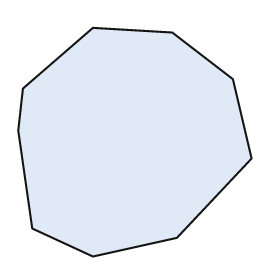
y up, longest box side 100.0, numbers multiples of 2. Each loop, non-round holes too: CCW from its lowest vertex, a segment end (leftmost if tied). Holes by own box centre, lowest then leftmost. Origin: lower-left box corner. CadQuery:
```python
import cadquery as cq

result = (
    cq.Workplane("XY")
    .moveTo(32.0, 0.0)
    .lineTo(68.0, 8.0)
    .lineTo(100.0, 42.0)
    .lineTo(92.0, 76.0)
    .lineTo(66.0, 96.0)
    .lineTo(32.0, 98.0)
    .lineTo(2.0, 72.0)
    .lineTo(0.0, 54.0)
    .lineTo(6.0, 12.0)
    .close()
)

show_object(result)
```